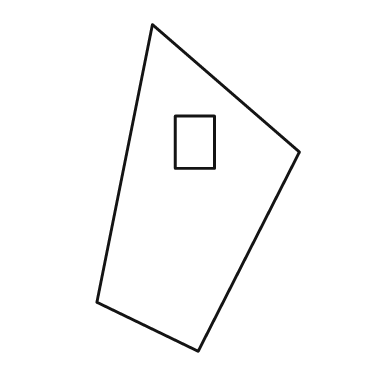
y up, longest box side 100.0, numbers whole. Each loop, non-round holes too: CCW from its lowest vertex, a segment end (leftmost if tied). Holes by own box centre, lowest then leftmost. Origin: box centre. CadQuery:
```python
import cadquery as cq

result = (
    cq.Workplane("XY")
    .moveTo(0.0, -50.0)
    .lineTo(31.0, 11.0)
    .lineTo(-14.0, 50.0)
    .lineTo(-31.0, -35.0)
    .close()
    .moveTo(-7.0, 6.0)
    .lineTo(5.0, 6.0)
    .lineTo(5.0, 22.0)
    .lineTo(-7.0, 22.0)
    .close()
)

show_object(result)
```